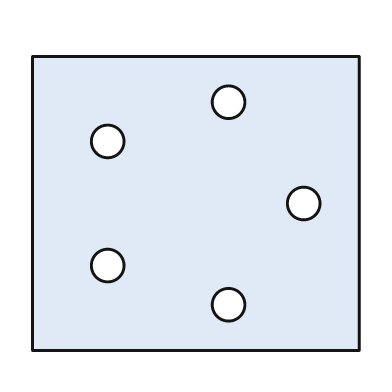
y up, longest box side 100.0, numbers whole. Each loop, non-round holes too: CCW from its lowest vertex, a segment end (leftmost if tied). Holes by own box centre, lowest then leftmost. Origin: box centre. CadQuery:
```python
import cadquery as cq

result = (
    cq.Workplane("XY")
    .moveTo(-50.0, -45.0)
    .lineTo(50.0, -45.0)
    .lineTo(50.0, 45.0)
    .lineTo(-50.0, 45.0)
    .close()
    .moveTo(10.0, -31.0)
    .circle(5.0)
    .moveTo(-27.0, -19.0)
    .circle(5.0)
    .moveTo(33.0, 0.0)
    .circle(5.0)
    .moveTo(-27.0, 19.0)
    .circle(5.0)
    .moveTo(10.0, 31.0)
    .circle(5.0)
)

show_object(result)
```